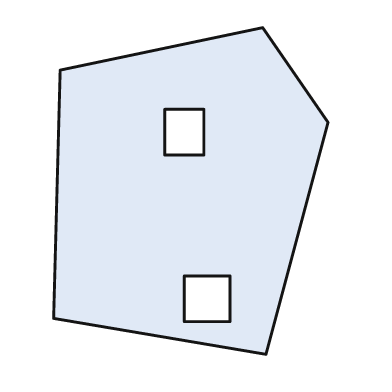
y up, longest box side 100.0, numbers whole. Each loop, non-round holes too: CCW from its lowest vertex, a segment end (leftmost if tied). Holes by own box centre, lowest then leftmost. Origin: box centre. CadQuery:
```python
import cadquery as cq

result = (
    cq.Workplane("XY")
    .moveTo(23.0, -50.0)
    .lineTo(42.0, 21.0)
    .lineTo(22.0, 50.0)
    .lineTo(-40.0, 37.0)
    .lineTo(-42.0, -39.0)
    .close()
    .moveTo(-2.0, -40.0)
    .lineTo(12.0, -40.0)
    .lineTo(12.0, -26.0)
    .lineTo(-2.0, -26.0)
    .close()
    .moveTo(-8.0, 11.0)
    .lineTo(4.0, 11.0)
    .lineTo(4.0, 25.0)
    .lineTo(-8.0, 25.0)
    .close()
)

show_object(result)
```